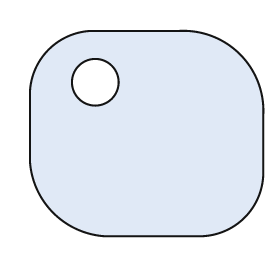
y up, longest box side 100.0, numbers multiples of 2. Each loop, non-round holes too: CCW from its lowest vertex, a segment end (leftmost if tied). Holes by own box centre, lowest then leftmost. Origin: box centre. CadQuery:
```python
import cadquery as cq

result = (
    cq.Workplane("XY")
    .moveTo(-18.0, -44.0)
    .lineTo(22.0, -44.0)
    .threePointArc((42.0, -36.0), (50.0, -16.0))
    .lineTo(50.0, 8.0)
    .threePointArc((40.0, 34.0), (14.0, 44.0))
    .lineTo(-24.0, 44.0)
    .threePointArc((-42.0, 36.0), (-50.0, 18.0))
    .lineTo(-50.0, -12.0)
    .threePointArc((-40.0, -34.0), (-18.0, -44.0))
    .close()
    .moveTo(-22.0, 22.0)
    .circle(10.0)
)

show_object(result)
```